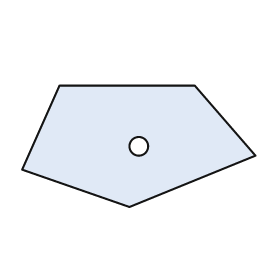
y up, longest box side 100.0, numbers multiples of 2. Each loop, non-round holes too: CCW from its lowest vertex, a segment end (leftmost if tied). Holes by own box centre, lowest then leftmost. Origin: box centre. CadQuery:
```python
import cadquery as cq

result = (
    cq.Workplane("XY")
    .moveTo(-4.0, -26.0)
    .lineTo(50.0, -4.0)
    .lineTo(24.0, 26.0)
    .lineTo(-34.0, 26.0)
    .lineTo(-50.0, -10.0)
    .close()
    .moveTo(0.0, 0.0)
    .circle(4.0)
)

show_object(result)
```